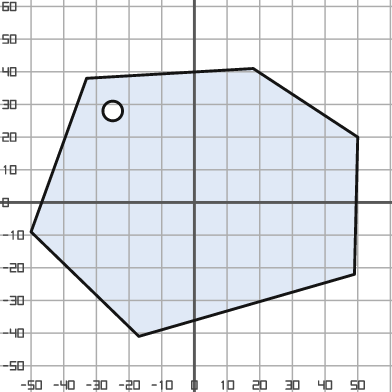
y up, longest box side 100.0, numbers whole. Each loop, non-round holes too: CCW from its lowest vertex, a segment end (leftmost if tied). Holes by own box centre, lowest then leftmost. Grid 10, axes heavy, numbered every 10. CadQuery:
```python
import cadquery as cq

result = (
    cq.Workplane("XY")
    .moveTo(-17.0, -41.0)
    .lineTo(49.0, -22.0)
    .lineTo(50.0, 20.0)
    .lineTo(18.0, 41.0)
    .lineTo(-33.0, 38.0)
    .lineTo(-50.0, -9.0)
    .close()
    .moveTo(-25.0, 28.0)
    .circle(3.0)
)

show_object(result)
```